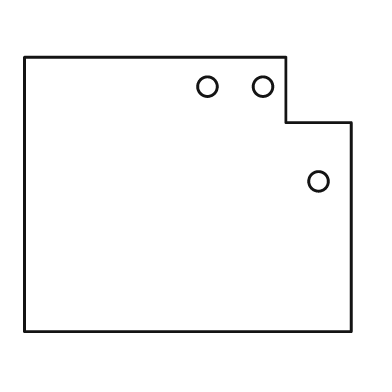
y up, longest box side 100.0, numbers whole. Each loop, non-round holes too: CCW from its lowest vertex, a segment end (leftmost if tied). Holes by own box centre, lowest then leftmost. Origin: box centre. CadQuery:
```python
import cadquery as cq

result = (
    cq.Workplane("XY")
    .moveTo(-50.0, -42.0)
    .lineTo(50.0, -42.0)
    .lineTo(50.0, 22.0)
    .lineTo(30.0, 22.0)
    .lineTo(30.0, 42.0)
    .lineTo(-50.0, 42.0)
    .close()
    .moveTo(40.0, 4.0)
    .circle(3.0)
    .moveTo(6.0, 33.0)
    .circle(3.0)
    .moveTo(23.0, 33.0)
    .circle(3.0)
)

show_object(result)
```